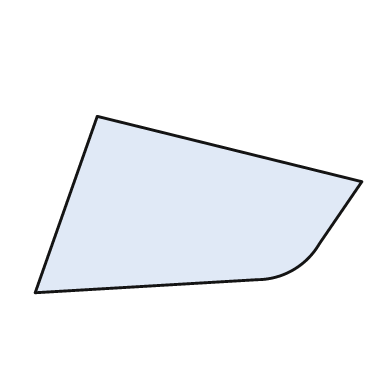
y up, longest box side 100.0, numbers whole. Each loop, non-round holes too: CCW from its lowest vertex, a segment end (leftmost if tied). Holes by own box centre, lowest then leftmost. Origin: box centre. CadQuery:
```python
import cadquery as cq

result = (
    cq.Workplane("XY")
    .moveTo(-50.0, -27.0)
    .lineTo(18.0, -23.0)
    .threePointArc((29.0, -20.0), (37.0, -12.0))
    .lineTo(50.0, 7.0)
    .lineTo(-31.0, 27.0)
    .close()
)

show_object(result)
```